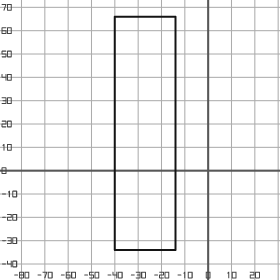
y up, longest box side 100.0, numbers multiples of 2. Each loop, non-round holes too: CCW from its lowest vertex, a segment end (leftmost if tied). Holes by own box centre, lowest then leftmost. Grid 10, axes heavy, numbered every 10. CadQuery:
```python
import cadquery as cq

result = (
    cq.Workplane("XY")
    .moveTo(-40.0, -34.0)
    .lineTo(-14.0, -34.0)
    .lineTo(-14.0, 66.0)
    .lineTo(-40.0, 66.0)
    .close()
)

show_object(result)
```